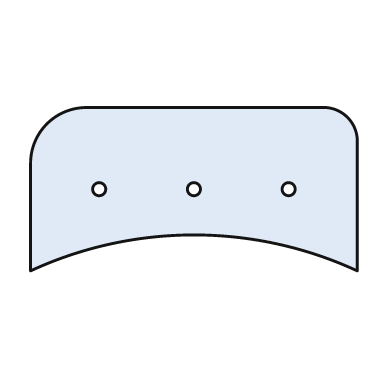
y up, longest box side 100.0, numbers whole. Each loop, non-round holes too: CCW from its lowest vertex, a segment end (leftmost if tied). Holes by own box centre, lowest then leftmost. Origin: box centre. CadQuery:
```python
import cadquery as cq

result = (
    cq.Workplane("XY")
    .moveTo(-50.0, -25.0)
    .threePointArc((0.0, -14.0), (50.0, -25.0))
    .lineTo(50.0, 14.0)
    .threePointArc((47.0, 22.0), (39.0, 25.0))
    .lineTo(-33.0, 25.0)
    .threePointArc((-45.0, 20.0), (-50.0, 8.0))
    .close()
    .moveTo(-29.0, 0.0)
    .circle(2.0)
    .moveTo(0.0, 0.0)
    .circle(2.0)
    .moveTo(29.0, 0.0)
    .circle(2.0)
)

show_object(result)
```